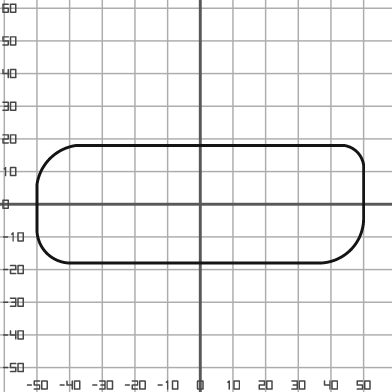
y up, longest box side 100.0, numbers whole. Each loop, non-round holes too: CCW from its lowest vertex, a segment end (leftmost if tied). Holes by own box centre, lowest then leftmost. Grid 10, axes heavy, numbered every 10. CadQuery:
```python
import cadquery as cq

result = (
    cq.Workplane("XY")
    .moveTo(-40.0, -18.0)
    .lineTo(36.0, -18.0)
    .threePointArc((46.0, -14.0), (50.0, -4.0))
    .lineTo(50.0, 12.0)
    .threePointArc((48.0, 16.0), (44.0, 18.0))
    .lineTo(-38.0, 18.0)
    .threePointArc((-46.0, 14.0), (-50.0, 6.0))
    .lineTo(-50.0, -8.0)
    .threePointArc((-47.0, -15.0), (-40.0, -18.0))
    .close()
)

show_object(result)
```